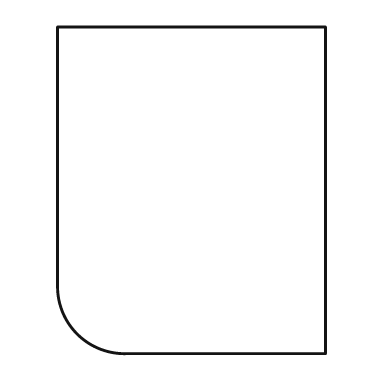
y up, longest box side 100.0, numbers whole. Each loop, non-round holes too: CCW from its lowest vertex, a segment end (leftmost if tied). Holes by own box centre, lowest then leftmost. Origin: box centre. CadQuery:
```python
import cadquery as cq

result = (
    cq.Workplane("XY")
    .moveTo(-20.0, -50.0)
    .lineTo(41.0, -50.0)
    .lineTo(41.0, 50.0)
    .lineTo(-41.0, 50.0)
    .lineTo(-41.0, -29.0)
    .threePointArc((-35.0, -44.0), (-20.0, -50.0))
    .close()
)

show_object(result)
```